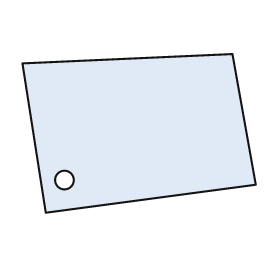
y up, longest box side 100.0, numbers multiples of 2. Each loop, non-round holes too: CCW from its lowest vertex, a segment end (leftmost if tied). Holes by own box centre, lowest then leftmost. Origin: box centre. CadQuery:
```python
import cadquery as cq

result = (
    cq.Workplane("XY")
    .moveTo(-40.0, -34.0)
    .lineTo(50.0, -22.0)
    .lineTo(40.0, 34.0)
    .lineTo(-50.0, 30.0)
    .close()
    .moveTo(-32.0, -20.0)
    .circle(4.0)
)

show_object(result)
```